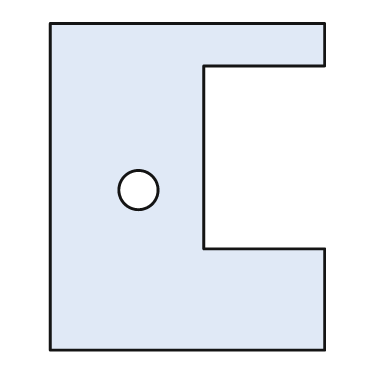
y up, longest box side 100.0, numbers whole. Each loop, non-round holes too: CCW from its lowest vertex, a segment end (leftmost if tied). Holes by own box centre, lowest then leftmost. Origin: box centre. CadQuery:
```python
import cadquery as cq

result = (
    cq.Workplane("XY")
    .moveTo(-42.0, -50.0)
    .lineTo(42.0, -50.0)
    .lineTo(42.0, -19.0)
    .lineTo(5.0, -19.0)
    .lineTo(5.0, 37.0)
    .lineTo(42.0, 37.0)
    .lineTo(42.0, 50.0)
    .lineTo(-42.0, 50.0)
    .close()
    .moveTo(-15.0, -1.0)
    .circle(6.0)
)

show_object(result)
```